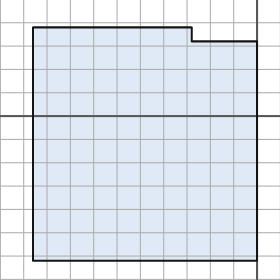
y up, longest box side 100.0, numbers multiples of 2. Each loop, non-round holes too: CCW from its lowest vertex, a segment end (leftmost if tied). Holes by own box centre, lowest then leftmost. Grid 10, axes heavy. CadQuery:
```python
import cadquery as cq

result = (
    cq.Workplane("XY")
    .moveTo(-96.0, -62.0)
    .lineTo(0.0, -62.0)
    .lineTo(0.0, 32.0)
    .lineTo(-28.0, 32.0)
    .lineTo(-28.0, 38.0)
    .lineTo(-96.0, 38.0)
    .close()
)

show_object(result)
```